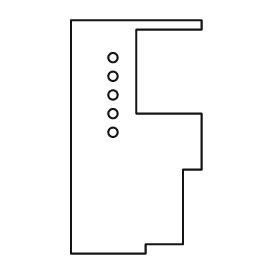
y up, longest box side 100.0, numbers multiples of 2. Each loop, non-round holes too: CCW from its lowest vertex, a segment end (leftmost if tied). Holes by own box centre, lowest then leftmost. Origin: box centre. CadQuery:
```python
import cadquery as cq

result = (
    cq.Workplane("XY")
    .moveTo(-28.0, -50.0)
    .lineTo(4.0, -50.0)
    .lineTo(4.0, -46.0)
    .lineTo(20.0, -46.0)
    .lineTo(20.0, -14.0)
    .lineTo(28.0, -14.0)
    .lineTo(28.0, 10.0)
    .lineTo(0.0, 10.0)
    .lineTo(0.0, 46.0)
    .lineTo(28.0, 46.0)
    .lineTo(28.0, 50.0)
    .lineTo(-28.0, 50.0)
    .close()
    .moveTo(-10.0, 2.0)
    .circle(2.0)
    .moveTo(-10.0, 10.0)
    .circle(2.0)
    .moveTo(-10.0, 18.0)
    .circle(2.0)
    .moveTo(-10.0, 26.0)
    .circle(2.0)
    .moveTo(-10.0, 34.0)
    .circle(2.0)
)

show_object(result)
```